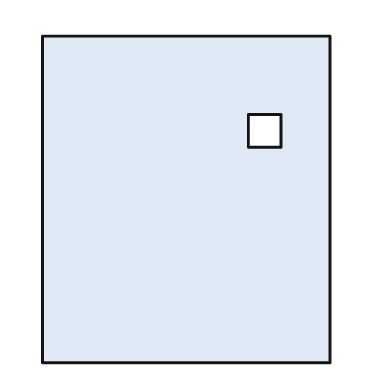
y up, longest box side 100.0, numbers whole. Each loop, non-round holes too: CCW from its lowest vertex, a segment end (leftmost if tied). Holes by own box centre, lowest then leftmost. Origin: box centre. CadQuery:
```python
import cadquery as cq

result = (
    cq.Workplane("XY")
    .moveTo(-44.0, -50.0)
    .lineTo(44.0, -50.0)
    .lineTo(44.0, 50.0)
    .lineTo(-44.0, 50.0)
    .close()
    .moveTo(19.0, 16.0)
    .lineTo(29.0, 16.0)
    .lineTo(29.0, 26.0)
    .lineTo(19.0, 26.0)
    .close()
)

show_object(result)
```